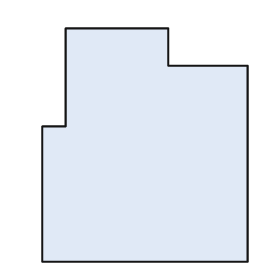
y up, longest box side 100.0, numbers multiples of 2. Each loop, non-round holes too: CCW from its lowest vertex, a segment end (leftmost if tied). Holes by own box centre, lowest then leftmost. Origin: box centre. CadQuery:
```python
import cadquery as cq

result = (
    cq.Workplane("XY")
    .moveTo(-44.0, -50.0)
    .lineTo(44.0, -50.0)
    .lineTo(44.0, 34.0)
    .lineTo(10.0, 34.0)
    .lineTo(10.0, 50.0)
    .lineTo(-34.0, 50.0)
    .lineTo(-34.0, 8.0)
    .lineTo(-44.0, 8.0)
    .close()
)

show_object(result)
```